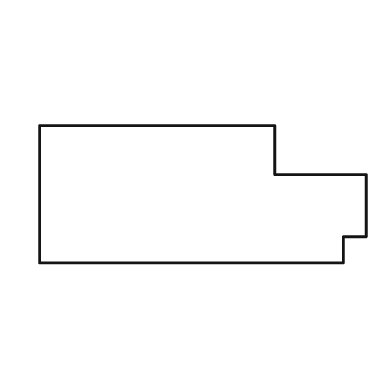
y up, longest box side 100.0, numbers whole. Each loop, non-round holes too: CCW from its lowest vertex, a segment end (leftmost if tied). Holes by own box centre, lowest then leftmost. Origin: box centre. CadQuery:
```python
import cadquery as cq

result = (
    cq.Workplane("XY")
    .moveTo(-50.0, -21.0)
    .lineTo(43.0, -21.0)
    .lineTo(43.0, -13.0)
    .lineTo(50.0, -13.0)
    .lineTo(50.0, 6.0)
    .lineTo(22.0, 6.0)
    .lineTo(22.0, 21.0)
    .lineTo(-50.0, 21.0)
    .close()
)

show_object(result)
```